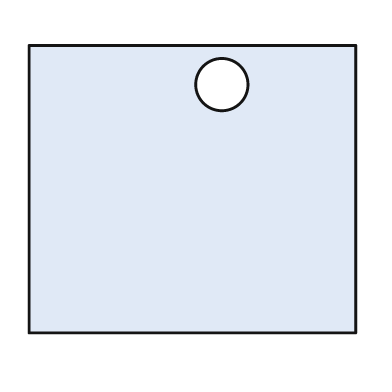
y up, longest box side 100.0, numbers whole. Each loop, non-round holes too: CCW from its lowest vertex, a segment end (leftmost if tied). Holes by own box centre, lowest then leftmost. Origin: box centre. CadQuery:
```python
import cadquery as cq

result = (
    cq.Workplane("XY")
    .moveTo(-50.0, -44.0)
    .lineTo(50.0, -44.0)
    .lineTo(50.0, 44.0)
    .lineTo(-50.0, 44.0)
    .close()
    .moveTo(9.0, 32.0)
    .circle(8.0)
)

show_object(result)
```